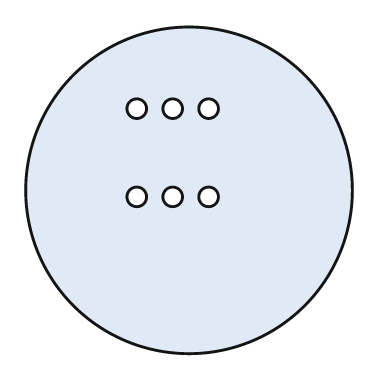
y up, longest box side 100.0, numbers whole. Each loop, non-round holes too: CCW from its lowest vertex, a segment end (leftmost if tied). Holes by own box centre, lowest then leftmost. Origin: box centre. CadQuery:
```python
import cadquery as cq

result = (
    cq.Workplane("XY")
    .moveTo(0.0, 0.0)
    .circle(50.0)
    .moveTo(-16.0, -2.0)
    .circle(3.0)
    .moveTo(-5.0, -2.0)
    .circle(3.0)
    .moveTo(6.0, -2.0)
    .circle(3.0)
    .moveTo(-16.0, 25.0)
    .circle(3.0)
    .moveTo(-5.0, 25.0)
    .circle(3.0)
    .moveTo(6.0, 25.0)
    .circle(3.0)
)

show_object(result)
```